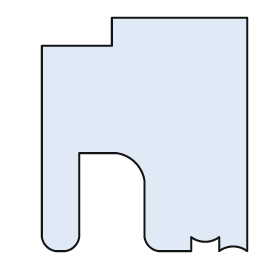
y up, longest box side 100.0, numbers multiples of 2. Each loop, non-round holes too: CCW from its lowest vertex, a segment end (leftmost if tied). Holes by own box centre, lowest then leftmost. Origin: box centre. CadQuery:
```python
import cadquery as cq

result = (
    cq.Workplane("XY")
    .moveTo(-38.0, -50.0)
    .lineTo(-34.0, -50.0)
    .threePointArc((-30.0, -48.0), (-28.0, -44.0))
    .lineTo(-28.0, -8.0)
    .lineTo(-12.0, -8.0)
    .threePointArc((-4.0, -12.0), (0.0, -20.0))
    .lineTo(0.0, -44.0)
    .threePointArc((2.0, -48.0), (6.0, -50.0))
    .lineTo(20.0, -50.0)
    .lineTo(20.0, -44.0)
    .threePointArc((26.0, -46.0), (32.0, -44.0))
    .lineTo(32.0, -50.0)
    .threePointArc((38.0, -48.0), (44.0, -50.0))
    .lineTo(44.0, 50.0)
    .lineTo(-14.0, 50.0)
    .lineTo(-14.0, 38.0)
    .lineTo(-44.0, 38.0)
    .lineTo(-44.0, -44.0)
    .threePointArc((-42.0, -48.0), (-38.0, -50.0))
    .close()
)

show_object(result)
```